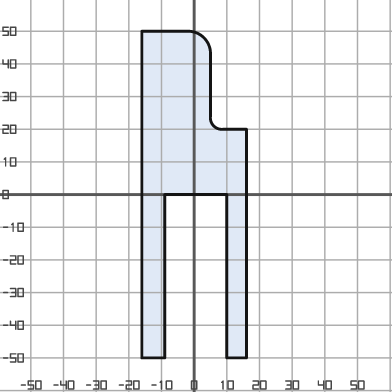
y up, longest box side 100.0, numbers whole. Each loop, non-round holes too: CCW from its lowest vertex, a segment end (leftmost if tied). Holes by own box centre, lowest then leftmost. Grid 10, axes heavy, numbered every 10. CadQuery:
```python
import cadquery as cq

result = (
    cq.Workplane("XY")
    .moveTo(-16.0, -50.0)
    .lineTo(-9.0, -50.0)
    .lineTo(-9.0, 0.0)
    .lineTo(10.0, 0.0)
    .lineTo(10.0, -50.0)
    .lineTo(16.0, -50.0)
    .lineTo(16.0, 20.0)
    .lineTo(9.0, 20.0)
    .threePointArc((6.0, 21.0), (5.0, 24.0))
    .lineTo(5.0, 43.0)
    .threePointArc((3.0, 48.0), (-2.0, 50.0))
    .lineTo(-16.0, 50.0)
    .close()
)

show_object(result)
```